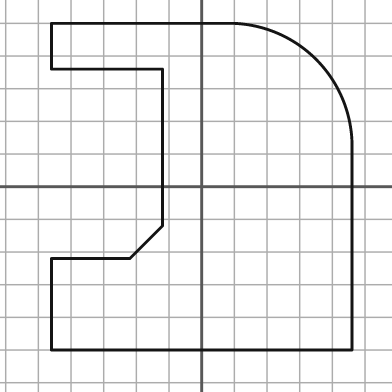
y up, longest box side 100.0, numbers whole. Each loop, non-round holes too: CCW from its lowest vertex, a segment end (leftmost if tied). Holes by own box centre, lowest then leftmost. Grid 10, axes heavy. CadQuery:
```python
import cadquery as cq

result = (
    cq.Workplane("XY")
    .moveTo(-46.0, -50.0)
    .lineTo(46.0, -50.0)
    .lineTo(46.0, 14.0)
    .threePointArc((35.0, 39.0), (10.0, 50.0))
    .lineTo(-46.0, 50.0)
    .lineTo(-46.0, 36.0)
    .lineTo(-12.0, 36.0)
    .lineTo(-12.0, -12.0)
    .lineTo(-22.0, -22.0)
    .lineTo(-46.0, -22.0)
    .close()
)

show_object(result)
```